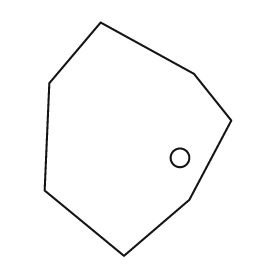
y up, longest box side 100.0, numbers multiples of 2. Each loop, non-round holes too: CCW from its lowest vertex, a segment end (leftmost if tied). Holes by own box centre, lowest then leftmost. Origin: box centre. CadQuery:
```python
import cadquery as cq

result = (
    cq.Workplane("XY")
    .moveTo(-6.0, -50.0)
    .lineTo(22.0, -26.0)
    .lineTo(40.0, 8.0)
    .lineTo(24.0, 28.0)
    .lineTo(-16.0, 50.0)
    .lineTo(-38.0, 24.0)
    .lineTo(-40.0, -22.0)
    .close()
    .moveTo(18.0, -8.0)
    .circle(4.0)
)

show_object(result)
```